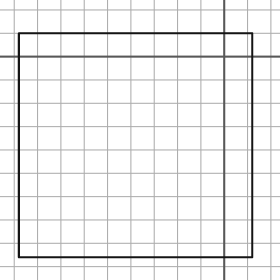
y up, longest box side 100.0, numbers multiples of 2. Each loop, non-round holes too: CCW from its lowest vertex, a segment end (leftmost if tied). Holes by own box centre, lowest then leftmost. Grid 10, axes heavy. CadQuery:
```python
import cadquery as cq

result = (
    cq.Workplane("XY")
    .moveTo(-88.0, -86.0)
    .lineTo(12.0, -86.0)
    .lineTo(12.0, 10.0)
    .lineTo(-88.0, 10.0)
    .close()
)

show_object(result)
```